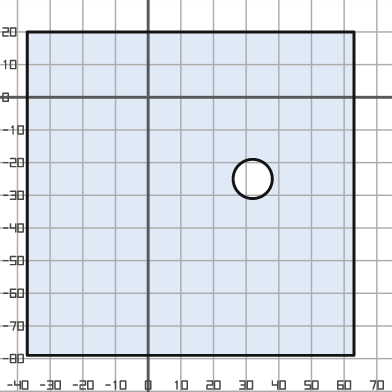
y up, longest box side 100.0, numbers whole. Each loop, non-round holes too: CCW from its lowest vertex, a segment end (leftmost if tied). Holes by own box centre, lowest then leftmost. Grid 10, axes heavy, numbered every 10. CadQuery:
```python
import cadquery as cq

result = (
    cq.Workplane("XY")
    .moveTo(-37.0, -79.0)
    .lineTo(63.0, -79.0)
    .lineTo(63.0, 20.0)
    .lineTo(-37.0, 20.0)
    .close()
    .moveTo(32.0, -25.0)
    .circle(6.0)
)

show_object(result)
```